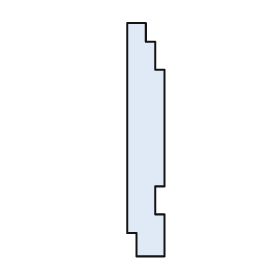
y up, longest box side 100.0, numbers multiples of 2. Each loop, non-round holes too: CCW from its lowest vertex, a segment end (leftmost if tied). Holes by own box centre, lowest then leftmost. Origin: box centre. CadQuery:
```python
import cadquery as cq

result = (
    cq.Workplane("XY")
    .moveTo(-4.0, -50.0)
    .lineTo(8.0, -50.0)
    .lineTo(8.0, -32.0)
    .lineTo(4.0, -32.0)
    .lineTo(4.0, -20.0)
    .lineTo(8.0, -20.0)
    .lineTo(8.0, 30.0)
    .lineTo(4.0, 30.0)
    .lineTo(4.0, 42.0)
    .lineTo(0.0, 42.0)
    .lineTo(0.0, 50.0)
    .lineTo(-8.0, 50.0)
    .lineTo(-8.0, -40.0)
    .lineTo(-4.0, -40.0)
    .close()
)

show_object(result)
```